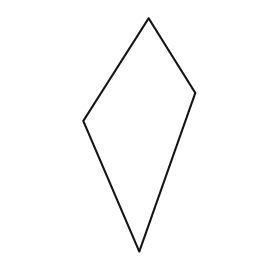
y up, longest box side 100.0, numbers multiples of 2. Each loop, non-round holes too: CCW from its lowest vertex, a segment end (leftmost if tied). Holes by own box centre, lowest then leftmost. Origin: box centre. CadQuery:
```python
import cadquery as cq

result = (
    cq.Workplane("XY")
    .moveTo(0.0, -50.0)
    .lineTo(24.0, 18.0)
    .lineTo(4.0, 50.0)
    .lineTo(-24.0, 6.0)
    .close()
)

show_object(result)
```